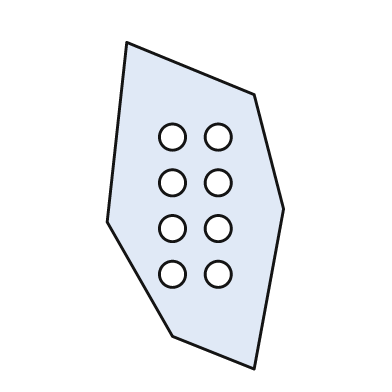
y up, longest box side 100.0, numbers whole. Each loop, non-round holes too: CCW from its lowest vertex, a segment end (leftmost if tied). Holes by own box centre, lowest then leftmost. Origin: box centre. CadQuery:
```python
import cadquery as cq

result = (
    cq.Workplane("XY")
    .moveTo(18.0, -50.0)
    .lineTo(27.0, -1.0)
    .lineTo(18.0, 34.0)
    .lineTo(-21.0, 50.0)
    .lineTo(-27.0, -5.0)
    .lineTo(-7.0, -40.0)
    .close()
    .moveTo(-7.0, -21.0)
    .circle(4.0)
    .moveTo(7.0, -21.0)
    .circle(4.0)
    .moveTo(-7.0, -7.0)
    .circle(4.0)
    .moveTo(7.0, -7.0)
    .circle(4.0)
    .moveTo(-7.0, 7.0)
    .circle(4.0)
    .moveTo(7.0, 7.0)
    .circle(4.0)
    .moveTo(-7.0, 21.0)
    .circle(4.0)
    .moveTo(7.0, 21.0)
    .circle(4.0)
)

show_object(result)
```